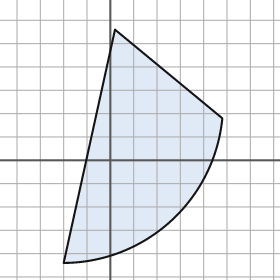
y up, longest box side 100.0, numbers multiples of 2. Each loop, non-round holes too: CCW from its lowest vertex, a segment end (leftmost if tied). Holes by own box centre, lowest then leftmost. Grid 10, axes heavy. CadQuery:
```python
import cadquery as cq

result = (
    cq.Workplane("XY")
    .moveTo(-20.0, -44.0)
    .threePointArc((26.0, -26.0), (48.0, 18.0))
    .lineTo(2.0, 56.0)
    .close()
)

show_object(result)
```